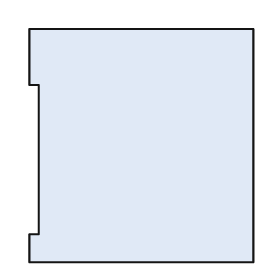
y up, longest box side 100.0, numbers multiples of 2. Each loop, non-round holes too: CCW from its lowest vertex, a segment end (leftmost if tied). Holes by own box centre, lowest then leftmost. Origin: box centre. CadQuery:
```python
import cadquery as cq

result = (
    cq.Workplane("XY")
    .moveTo(-48.0, -50.0)
    .lineTo(48.0, -50.0)
    .lineTo(48.0, 50.0)
    .lineTo(-48.0, 50.0)
    .lineTo(-48.0, 26.0)
    .lineTo(-44.0, 26.0)
    .lineTo(-44.0, -38.0)
    .lineTo(-48.0, -38.0)
    .close()
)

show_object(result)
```